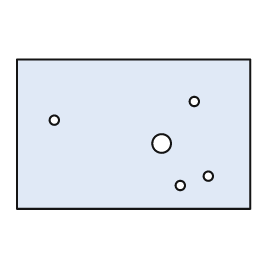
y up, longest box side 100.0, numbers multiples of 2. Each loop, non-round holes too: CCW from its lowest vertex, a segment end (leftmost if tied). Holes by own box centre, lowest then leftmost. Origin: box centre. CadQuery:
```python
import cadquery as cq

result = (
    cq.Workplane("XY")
    .moveTo(-50.0, -32.0)
    .lineTo(50.0, -32.0)
    .lineTo(50.0, 32.0)
    .lineTo(-50.0, 32.0)
    .close()
    .moveTo(20.0, -22.0)
    .circle(2.0)
    .moveTo(32.0, -18.0)
    .circle(2.0)
    .moveTo(12.0, -4.0)
    .circle(4.0)
    .moveTo(-34.0, 6.0)
    .circle(2.0)
    .moveTo(26.0, 14.0)
    .circle(2.0)
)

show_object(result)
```